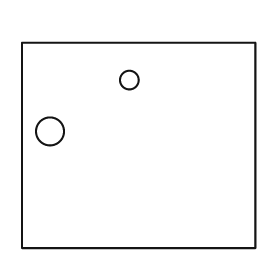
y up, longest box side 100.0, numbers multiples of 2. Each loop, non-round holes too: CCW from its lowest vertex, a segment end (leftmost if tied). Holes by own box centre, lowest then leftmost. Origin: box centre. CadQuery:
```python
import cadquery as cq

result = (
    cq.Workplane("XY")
    .moveTo(-50.0, -44.0)
    .lineTo(50.0, -44.0)
    .lineTo(50.0, 44.0)
    .lineTo(-50.0, 44.0)
    .close()
    .moveTo(-38.0, 6.0)
    .circle(6.0)
    .moveTo(-4.0, 28.0)
    .circle(4.0)
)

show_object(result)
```